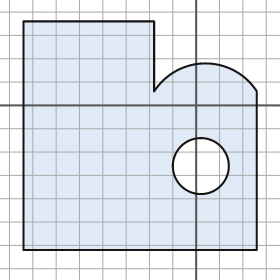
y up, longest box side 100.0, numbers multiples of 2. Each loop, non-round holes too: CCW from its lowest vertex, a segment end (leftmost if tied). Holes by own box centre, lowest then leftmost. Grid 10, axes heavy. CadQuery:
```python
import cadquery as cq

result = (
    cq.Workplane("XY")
    .moveTo(-74.0, -62.0)
    .lineTo(26.0, -62.0)
    .lineTo(26.0, 6.0)
    .threePointArc((4.0, 18.0), (-18.0, 6.0))
    .lineTo(-18.0, 36.0)
    .lineTo(-74.0, 36.0)
    .close()
    .moveTo(2.0, -26.0)
    .circle(12.0)
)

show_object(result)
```